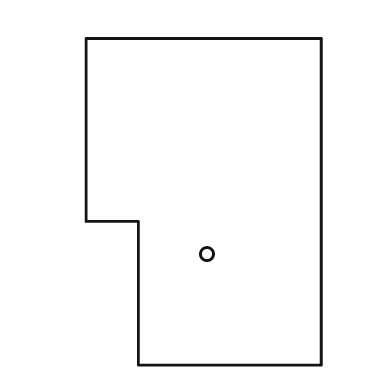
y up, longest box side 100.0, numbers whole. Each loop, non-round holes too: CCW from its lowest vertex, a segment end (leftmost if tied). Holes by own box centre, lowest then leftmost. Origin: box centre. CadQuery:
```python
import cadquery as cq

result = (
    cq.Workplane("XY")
    .moveTo(-20.0, -50.0)
    .lineTo(36.0, -50.0)
    .lineTo(36.0, 50.0)
    .lineTo(-36.0, 50.0)
    .lineTo(-36.0, -6.0)
    .lineTo(-20.0, -6.0)
    .close()
    .moveTo(1.0, -16.0)
    .circle(2.0)
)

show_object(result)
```